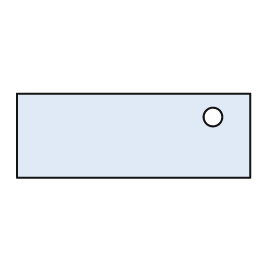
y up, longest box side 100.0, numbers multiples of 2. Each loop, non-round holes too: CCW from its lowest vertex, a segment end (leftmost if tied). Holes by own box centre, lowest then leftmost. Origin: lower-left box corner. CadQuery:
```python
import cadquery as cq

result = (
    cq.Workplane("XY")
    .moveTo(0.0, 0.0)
    .lineTo(100.0, 0.0)
    .lineTo(100.0, 36.0)
    .lineTo(0.0, 36.0)
    .close()
    .moveTo(84.0, 26.0)
    .circle(4.0)
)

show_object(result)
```